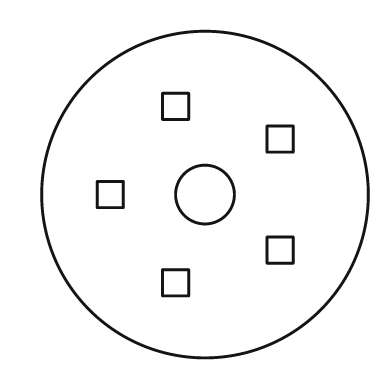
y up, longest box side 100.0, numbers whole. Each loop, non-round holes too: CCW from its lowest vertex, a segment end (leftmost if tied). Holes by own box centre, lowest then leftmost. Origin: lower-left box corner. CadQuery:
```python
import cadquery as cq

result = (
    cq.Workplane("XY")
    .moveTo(50.0, 50.0)
    .circle(50.0)
    .moveTo(37.0, 19.0)
    .lineTo(45.0, 19.0)
    .lineTo(45.0, 27.0)
    .lineTo(37.0, 27.0)
    .close()
    .moveTo(69.0, 29.0)
    .lineTo(77.0, 29.0)
    .lineTo(77.0, 37.0)
    .lineTo(69.0, 37.0)
    .close()
    .moveTo(17.0, 46.0)
    .lineTo(25.0, 46.0)
    .lineTo(25.0, 54.0)
    .lineTo(17.0, 54.0)
    .close()
    .moveTo(50.0, 50.0)
    .circle(9.0)
    .moveTo(69.0, 63.0)
    .lineTo(77.0, 63.0)
    .lineTo(77.0, 71.0)
    .lineTo(69.0, 71.0)
    .close()
    .moveTo(37.0, 73.0)
    .lineTo(45.0, 73.0)
    .lineTo(45.0, 81.0)
    .lineTo(37.0, 81.0)
    .close()
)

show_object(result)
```